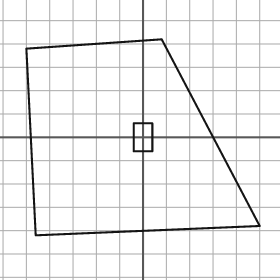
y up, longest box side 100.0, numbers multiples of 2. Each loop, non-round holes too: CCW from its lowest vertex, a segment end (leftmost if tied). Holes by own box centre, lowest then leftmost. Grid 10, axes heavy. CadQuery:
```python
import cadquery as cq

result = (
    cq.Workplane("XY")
    .moveTo(-46.0, -42.0)
    .lineTo(50.0, -38.0)
    .lineTo(8.0, 42.0)
    .lineTo(-50.0, 38.0)
    .close()
    .moveTo(-4.0, -6.0)
    .lineTo(4.0, -6.0)
    .lineTo(4.0, 6.0)
    .lineTo(-4.0, 6.0)
    .close()
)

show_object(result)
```